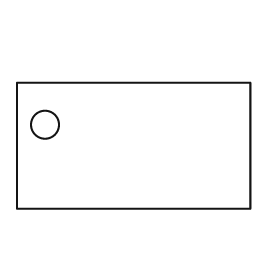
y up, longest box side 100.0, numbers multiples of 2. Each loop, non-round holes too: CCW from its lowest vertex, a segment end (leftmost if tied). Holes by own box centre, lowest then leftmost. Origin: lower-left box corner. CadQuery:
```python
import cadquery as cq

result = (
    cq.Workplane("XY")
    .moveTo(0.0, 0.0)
    .lineTo(100.0, 0.0)
    .lineTo(100.0, 54.0)
    .lineTo(0.0, 54.0)
    .close()
    .moveTo(12.0, 36.0)
    .circle(6.0)
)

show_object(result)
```